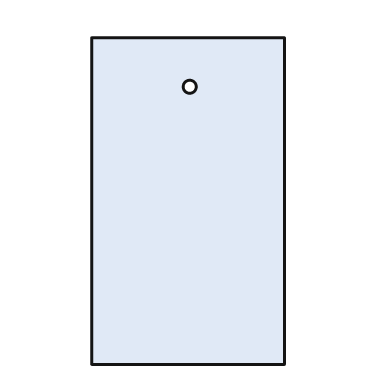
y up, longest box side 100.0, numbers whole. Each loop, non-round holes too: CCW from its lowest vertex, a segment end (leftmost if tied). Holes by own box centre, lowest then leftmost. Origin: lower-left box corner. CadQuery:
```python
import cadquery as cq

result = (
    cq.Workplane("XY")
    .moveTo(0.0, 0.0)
    .lineTo(59.0, 0.0)
    .lineTo(59.0, 100.0)
    .lineTo(0.0, 100.0)
    .close()
    .moveTo(30.0, 85.0)
    .circle(2.0)
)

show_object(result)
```